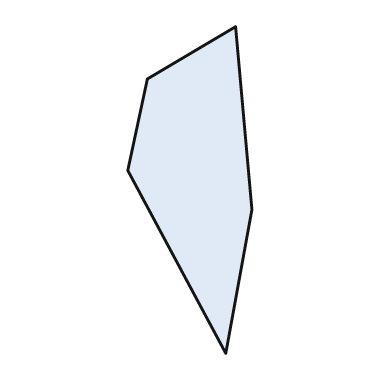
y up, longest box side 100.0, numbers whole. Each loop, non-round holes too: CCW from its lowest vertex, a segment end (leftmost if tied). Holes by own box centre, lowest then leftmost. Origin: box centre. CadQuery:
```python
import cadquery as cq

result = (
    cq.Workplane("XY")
    .moveTo(11.0, -50.0)
    .lineTo(19.0, -6.0)
    .lineTo(14.0, 50.0)
    .lineTo(-13.0, 34.0)
    .lineTo(-19.0, 6.0)
    .close()
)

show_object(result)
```